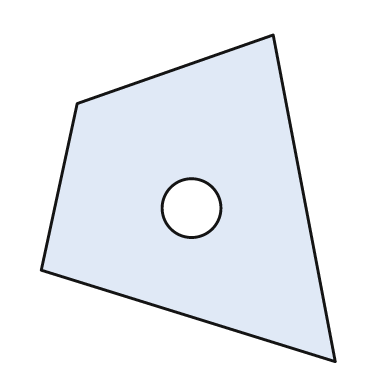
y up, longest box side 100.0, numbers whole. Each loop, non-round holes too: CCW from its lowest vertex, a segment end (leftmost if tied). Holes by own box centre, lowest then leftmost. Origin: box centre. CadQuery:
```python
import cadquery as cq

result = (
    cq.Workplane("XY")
    .moveTo(45.0, -50.0)
    .lineTo(26.0, 50.0)
    .lineTo(-34.0, 29.0)
    .lineTo(-45.0, -22.0)
    .close()
    .moveTo(1.0, -3.0)
    .circle(9.0)
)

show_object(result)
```